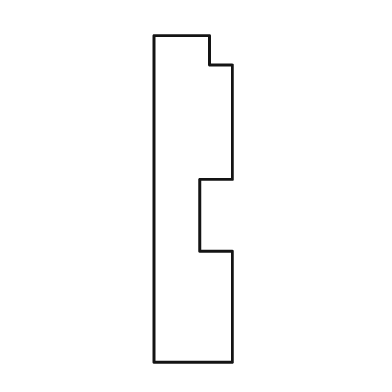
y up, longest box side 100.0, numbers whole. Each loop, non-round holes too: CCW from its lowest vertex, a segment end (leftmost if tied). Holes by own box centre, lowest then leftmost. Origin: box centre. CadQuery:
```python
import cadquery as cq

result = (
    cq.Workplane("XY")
    .moveTo(-12.0, -50.0)
    .lineTo(12.0, -50.0)
    .lineTo(12.0, -16.0)
    .lineTo(2.0, -16.0)
    .lineTo(2.0, 6.0)
    .lineTo(12.0, 6.0)
    .lineTo(12.0, 41.0)
    .lineTo(5.0, 41.0)
    .lineTo(5.0, 50.0)
    .lineTo(-12.0, 50.0)
    .close()
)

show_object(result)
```